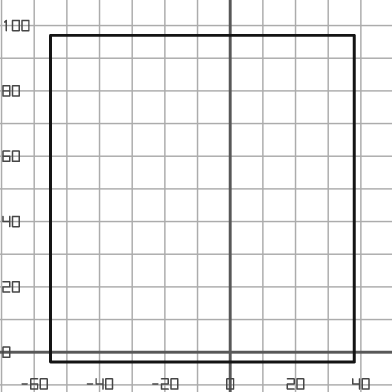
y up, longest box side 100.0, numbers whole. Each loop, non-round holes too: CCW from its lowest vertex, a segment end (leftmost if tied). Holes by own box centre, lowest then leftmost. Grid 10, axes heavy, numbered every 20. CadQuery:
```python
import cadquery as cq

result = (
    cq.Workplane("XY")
    .moveTo(-55.0, -3.0)
    .lineTo(38.0, -3.0)
    .lineTo(38.0, 97.0)
    .lineTo(-55.0, 97.0)
    .close()
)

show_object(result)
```